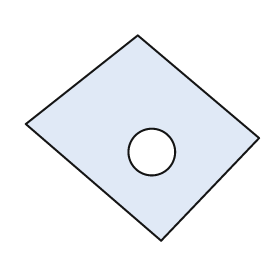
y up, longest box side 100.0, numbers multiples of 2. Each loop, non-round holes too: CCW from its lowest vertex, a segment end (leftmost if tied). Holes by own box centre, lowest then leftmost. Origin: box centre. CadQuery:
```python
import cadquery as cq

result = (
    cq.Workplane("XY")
    .moveTo(8.0, -44.0)
    .lineTo(50.0, 0.0)
    .lineTo(-2.0, 44.0)
    .lineTo(-50.0, 6.0)
    .close()
    .moveTo(4.0, -6.0)
    .circle(10.0)
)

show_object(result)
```